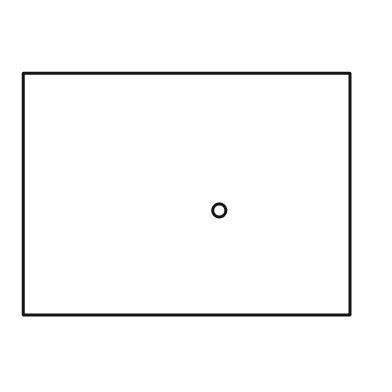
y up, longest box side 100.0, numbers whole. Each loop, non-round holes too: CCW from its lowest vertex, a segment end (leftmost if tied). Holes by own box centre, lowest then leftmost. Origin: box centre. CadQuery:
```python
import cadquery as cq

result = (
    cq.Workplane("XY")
    .moveTo(-50.0, -37.0)
    .lineTo(50.0, -37.0)
    .lineTo(50.0, 37.0)
    .lineTo(-50.0, 37.0)
    .close()
    .moveTo(10.0, -5.0)
    .circle(2.0)
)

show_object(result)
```